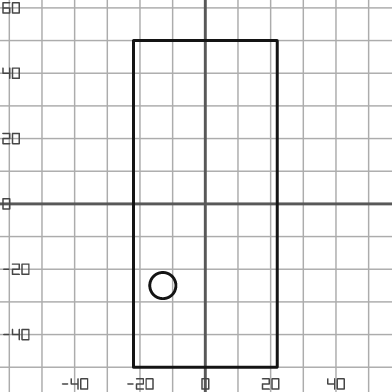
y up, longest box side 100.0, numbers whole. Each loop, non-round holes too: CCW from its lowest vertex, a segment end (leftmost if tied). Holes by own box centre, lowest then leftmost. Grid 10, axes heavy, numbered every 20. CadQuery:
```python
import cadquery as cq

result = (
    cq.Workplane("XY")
    .moveTo(-22.0, -50.0)
    .lineTo(22.0, -50.0)
    .lineTo(22.0, 50.0)
    .lineTo(-22.0, 50.0)
    .close()
    .moveTo(-13.0, -25.0)
    .circle(4.0)
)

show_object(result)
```